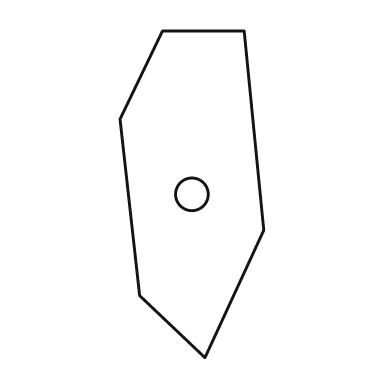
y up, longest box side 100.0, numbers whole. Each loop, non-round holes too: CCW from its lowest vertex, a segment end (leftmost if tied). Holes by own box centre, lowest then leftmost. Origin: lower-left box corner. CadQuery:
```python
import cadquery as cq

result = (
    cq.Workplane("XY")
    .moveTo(26.0, 0.0)
    .lineTo(44.0, 39.0)
    .lineTo(38.0, 100.0)
    .lineTo(13.0, 100.0)
    .lineTo(0.0, 73.0)
    .lineTo(6.0, 19.0)
    .close()
    .moveTo(22.0, 50.0)
    .circle(5.0)
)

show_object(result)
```